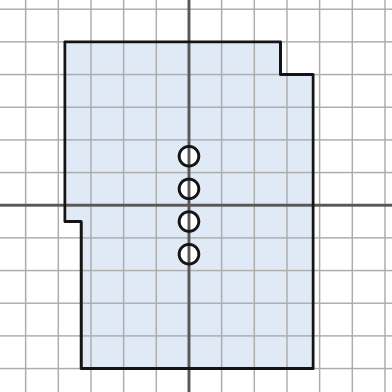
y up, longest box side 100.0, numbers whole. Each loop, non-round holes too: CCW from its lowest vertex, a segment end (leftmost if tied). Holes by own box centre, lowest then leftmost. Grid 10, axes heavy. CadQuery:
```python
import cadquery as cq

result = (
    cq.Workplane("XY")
    .moveTo(-33.0, -50.0)
    .lineTo(38.0, -50.0)
    .lineTo(38.0, 40.0)
    .lineTo(28.0, 40.0)
    .lineTo(28.0, 50.0)
    .lineTo(-38.0, 50.0)
    .lineTo(-38.0, -5.0)
    .lineTo(-33.0, -5.0)
    .close()
    .moveTo(0.0, -15.0)
    .circle(3.0)
    .moveTo(0.0, -5.0)
    .circle(3.0)
    .moveTo(0.0, 5.0)
    .circle(3.0)
    .moveTo(0.0, 15.0)
    .circle(3.0)
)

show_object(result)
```